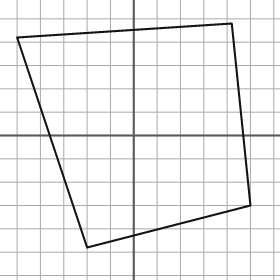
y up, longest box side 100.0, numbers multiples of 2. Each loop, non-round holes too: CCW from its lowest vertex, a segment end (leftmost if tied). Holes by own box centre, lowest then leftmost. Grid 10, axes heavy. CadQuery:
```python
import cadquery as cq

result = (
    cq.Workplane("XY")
    .moveTo(-20.0, -48.0)
    .lineTo(50.0, -30.0)
    .lineTo(42.0, 48.0)
    .lineTo(-50.0, 42.0)
    .close()
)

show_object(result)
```